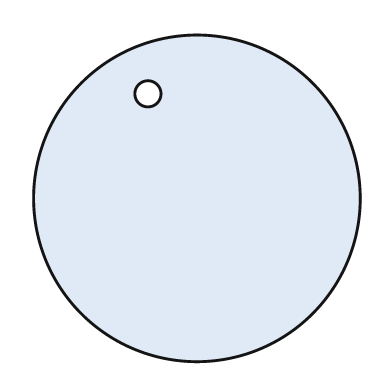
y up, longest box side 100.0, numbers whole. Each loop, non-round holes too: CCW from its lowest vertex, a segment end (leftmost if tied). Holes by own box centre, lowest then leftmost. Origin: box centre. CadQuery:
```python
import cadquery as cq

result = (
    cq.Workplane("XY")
    .moveTo(0.0, 0.0)
    .circle(50.0)
    .moveTo(-15.0, 32.0)
    .circle(4.0)
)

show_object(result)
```